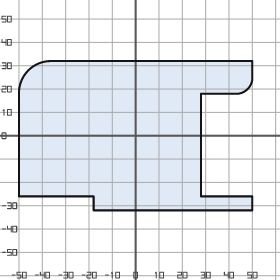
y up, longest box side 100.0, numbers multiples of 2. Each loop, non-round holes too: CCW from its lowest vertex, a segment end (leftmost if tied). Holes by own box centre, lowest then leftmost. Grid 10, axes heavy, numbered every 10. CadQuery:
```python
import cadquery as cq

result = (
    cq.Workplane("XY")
    .moveTo(-18.0, -32.0)
    .lineTo(50.0, -32.0)
    .lineTo(50.0, -26.0)
    .lineTo(28.0, -26.0)
    .lineTo(28.0, 18.0)
    .lineTo(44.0, 18.0)
    .threePointArc((48.0, 20.0), (50.0, 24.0))
    .lineTo(50.0, 32.0)
    .lineTo(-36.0, 32.0)
    .threePointArc((-46.0, 28.0), (-50.0, 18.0))
    .lineTo(-50.0, -26.0)
    .lineTo(-18.0, -26.0)
    .close()
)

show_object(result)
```